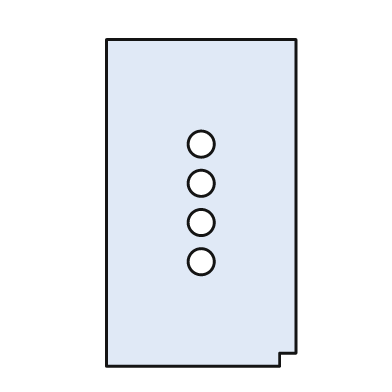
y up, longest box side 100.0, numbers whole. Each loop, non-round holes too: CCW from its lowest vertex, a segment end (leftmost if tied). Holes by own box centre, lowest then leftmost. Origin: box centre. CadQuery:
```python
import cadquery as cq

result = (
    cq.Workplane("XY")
    .moveTo(-29.0, -50.0)
    .lineTo(24.0, -50.0)
    .lineTo(24.0, -46.0)
    .lineTo(29.0, -46.0)
    .lineTo(29.0, 50.0)
    .lineTo(-29.0, 50.0)
    .close()
    .moveTo(0.0, -18.0)
    .circle(4.0)
    .moveTo(0.0, -6.0)
    .circle(4.0)
    .moveTo(0.0, 6.0)
    .circle(4.0)
    .moveTo(0.0, 18.0)
    .circle(4.0)
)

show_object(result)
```